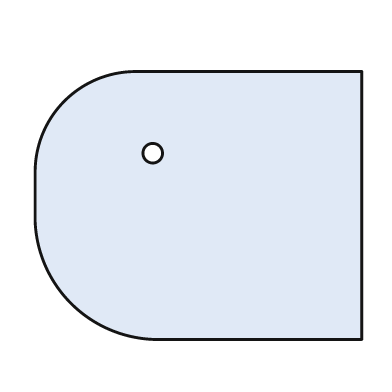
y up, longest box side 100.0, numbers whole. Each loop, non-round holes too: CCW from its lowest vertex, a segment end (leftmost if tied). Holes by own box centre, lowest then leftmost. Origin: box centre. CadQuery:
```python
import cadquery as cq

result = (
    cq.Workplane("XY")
    .moveTo(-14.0, -41.0)
    .lineTo(50.0, -41.0)
    .lineTo(50.0, 41.0)
    .lineTo(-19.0, 41.0)
    .threePointArc((-41.0, 32.0), (-50.0, 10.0))
    .lineTo(-50.0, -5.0)
    .threePointArc((-39.0, -30.0), (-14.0, -41.0))
    .close()
    .moveTo(-14.0, 16.0)
    .circle(3.0)
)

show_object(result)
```